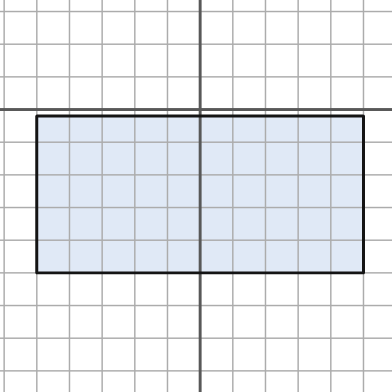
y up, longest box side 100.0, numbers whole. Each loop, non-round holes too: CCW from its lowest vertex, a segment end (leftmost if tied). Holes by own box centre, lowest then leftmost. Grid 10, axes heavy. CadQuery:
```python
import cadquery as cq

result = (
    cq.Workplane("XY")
    .moveTo(-50.0, -50.0)
    .lineTo(50.0, -50.0)
    .lineTo(50.0, -2.0)
    .lineTo(-50.0, -2.0)
    .close()
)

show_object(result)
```